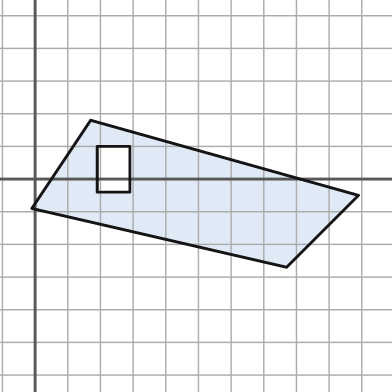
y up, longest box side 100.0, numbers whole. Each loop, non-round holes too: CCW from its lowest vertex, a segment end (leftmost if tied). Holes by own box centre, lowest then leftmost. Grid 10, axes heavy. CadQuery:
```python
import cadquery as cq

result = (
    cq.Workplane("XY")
    .moveTo(77.0, -27.0)
    .lineTo(99.0, -5.0)
    .lineTo(17.0, 18.0)
    .lineTo(-1.0, -9.0)
    .close()
    .moveTo(19.0, -4.0)
    .lineTo(29.0, -4.0)
    .lineTo(29.0, 10.0)
    .lineTo(19.0, 10.0)
    .close()
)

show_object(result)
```